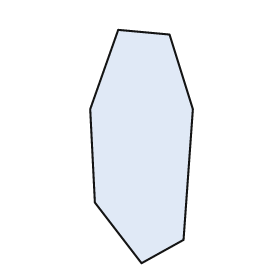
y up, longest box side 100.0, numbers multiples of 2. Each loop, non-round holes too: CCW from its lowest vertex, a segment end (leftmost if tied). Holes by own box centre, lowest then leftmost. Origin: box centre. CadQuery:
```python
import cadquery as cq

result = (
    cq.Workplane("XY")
    .moveTo(0.0, -50.0)
    .lineTo(18.0, -40.0)
    .lineTo(22.0, 16.0)
    .lineTo(12.0, 48.0)
    .lineTo(-10.0, 50.0)
    .lineTo(-22.0, 16.0)
    .lineTo(-20.0, -24.0)
    .close()
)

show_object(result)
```